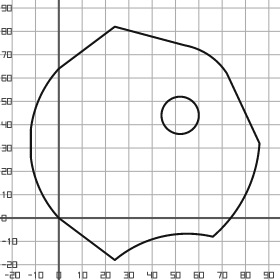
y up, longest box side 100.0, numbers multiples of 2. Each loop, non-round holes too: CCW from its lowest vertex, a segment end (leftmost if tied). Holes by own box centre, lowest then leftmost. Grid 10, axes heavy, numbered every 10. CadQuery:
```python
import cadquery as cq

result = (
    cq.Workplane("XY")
    .moveTo(24.0, -18.0)
    .threePointArc((44.0, -8.0), (66.0, -8.0))
    .threePointArc((80.0, 10.0), (86.0, 32.0))
    .lineTo(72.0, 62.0)
    .threePointArc((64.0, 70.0), (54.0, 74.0))
    .lineTo(24.0, 82.0)
    .lineTo(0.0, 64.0)
    .threePointArc((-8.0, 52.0), (-12.0, 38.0))
    .lineTo(-12.0, 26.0)
    .threePointArc((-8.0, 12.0), (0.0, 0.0))
    .close()
    .moveTo(52.0, 44.0)
    .circle(8.0)
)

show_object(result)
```